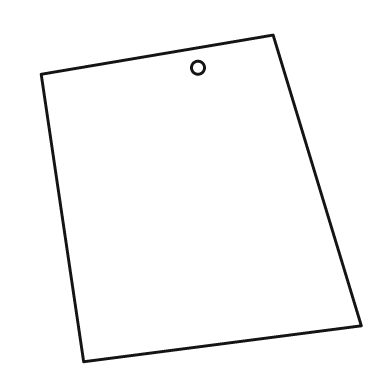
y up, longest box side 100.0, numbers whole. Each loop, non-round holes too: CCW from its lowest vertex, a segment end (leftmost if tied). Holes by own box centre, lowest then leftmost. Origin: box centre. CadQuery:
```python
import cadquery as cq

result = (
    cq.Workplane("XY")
    .moveTo(-36.0, -50.0)
    .lineTo(49.0, -39.0)
    .lineTo(22.0, 50.0)
    .lineTo(-49.0, 38.0)
    .close()
    .moveTo(-1.0, 40.0)
    .circle(2.0)
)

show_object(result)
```